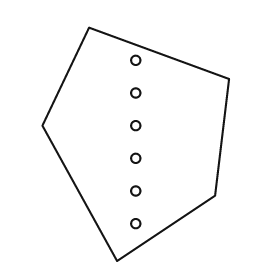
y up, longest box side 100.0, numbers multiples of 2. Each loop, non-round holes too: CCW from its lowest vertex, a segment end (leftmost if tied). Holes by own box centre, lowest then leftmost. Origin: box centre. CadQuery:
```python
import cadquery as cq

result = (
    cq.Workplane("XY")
    .moveTo(-8.0, -50.0)
    .lineTo(34.0, -22.0)
    .lineTo(40.0, 28.0)
    .lineTo(-20.0, 50.0)
    .lineTo(-40.0, 8.0)
    .close()
    .moveTo(0.0, -34.0)
    .circle(2.0)
    .moveTo(0.0, -20.0)
    .circle(2.0)
    .moveTo(0.0, -6.0)
    .circle(2.0)
    .moveTo(0.0, 8.0)
    .circle(2.0)
    .moveTo(0.0, 22.0)
    .circle(2.0)
    .moveTo(0.0, 36.0)
    .circle(2.0)
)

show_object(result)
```